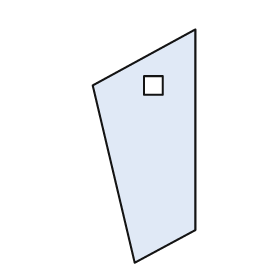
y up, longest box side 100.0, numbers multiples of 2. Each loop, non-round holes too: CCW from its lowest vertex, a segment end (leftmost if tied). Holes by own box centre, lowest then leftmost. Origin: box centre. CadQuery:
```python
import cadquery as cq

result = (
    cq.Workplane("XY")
    .moveTo(-4.0, -50.0)
    .lineTo(22.0, -36.0)
    .lineTo(22.0, 50.0)
    .lineTo(-22.0, 26.0)
    .close()
    .moveTo(0.0, 22.0)
    .lineTo(8.0, 22.0)
    .lineTo(8.0, 30.0)
    .lineTo(0.0, 30.0)
    .close()
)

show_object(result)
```